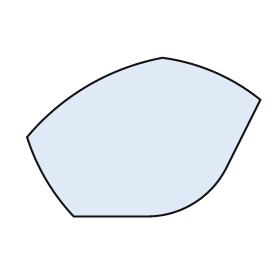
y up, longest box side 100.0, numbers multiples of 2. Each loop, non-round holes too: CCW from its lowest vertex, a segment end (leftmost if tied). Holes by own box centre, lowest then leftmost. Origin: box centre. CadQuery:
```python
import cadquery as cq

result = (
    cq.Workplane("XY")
    .moveTo(-30.0, -34.0)
    .lineTo(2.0, -34.0)
    .threePointArc((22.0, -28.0), (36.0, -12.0))
    .lineTo(50.0, 16.0)
    .threePointArc((30.0, 28.0), (8.0, 34.0))
    .threePointArc((-24.0, 22.0), (-50.0, 0.0))
    .threePointArc((-42.0, -18.0), (-30.0, -34.0))
    .close()
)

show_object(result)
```